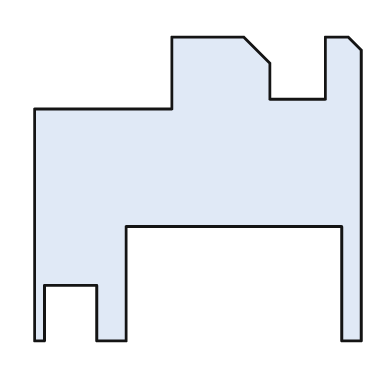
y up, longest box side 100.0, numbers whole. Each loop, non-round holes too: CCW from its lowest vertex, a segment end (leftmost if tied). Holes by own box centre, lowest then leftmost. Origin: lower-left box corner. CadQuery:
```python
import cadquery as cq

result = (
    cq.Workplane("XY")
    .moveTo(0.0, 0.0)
    .lineTo(3.0, 0.0)
    .lineTo(3.0, 17.0)
    .lineTo(19.0, 17.0)
    .lineTo(19.0, 0.0)
    .lineTo(28.0, 0.0)
    .lineTo(28.0, 35.0)
    .lineTo(94.0, 35.0)
    .lineTo(94.0, 0.0)
    .lineTo(100.0, 0.0)
    .lineTo(100.0, 89.0)
    .lineTo(96.0, 93.0)
    .lineTo(89.0, 93.0)
    .lineTo(89.0, 74.0)
    .lineTo(72.0, 74.0)
    .lineTo(72.0, 85.0)
    .lineTo(64.0, 93.0)
    .lineTo(42.0, 93.0)
    .lineTo(42.0, 71.0)
    .lineTo(0.0, 71.0)
    .close()
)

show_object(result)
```